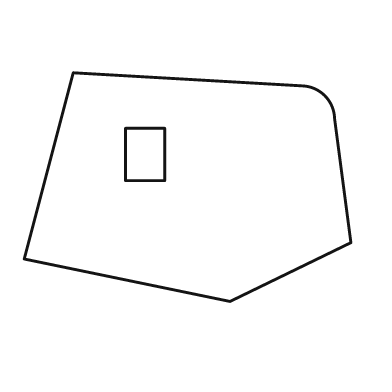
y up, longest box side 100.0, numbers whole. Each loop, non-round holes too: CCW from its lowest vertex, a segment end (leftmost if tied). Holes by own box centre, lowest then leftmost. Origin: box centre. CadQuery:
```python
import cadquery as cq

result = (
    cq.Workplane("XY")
    .moveTo(13.0, -35.0)
    .lineTo(50.0, -17.0)
    .lineTo(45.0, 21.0)
    .threePointArc((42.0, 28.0), (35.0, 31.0))
    .lineTo(-35.0, 35.0)
    .lineTo(-50.0, -22.0)
    .close()
    .moveTo(-19.0, 2.0)
    .lineTo(-7.0, 2.0)
    .lineTo(-7.0, 18.0)
    .lineTo(-19.0, 18.0)
    .close()
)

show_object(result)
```